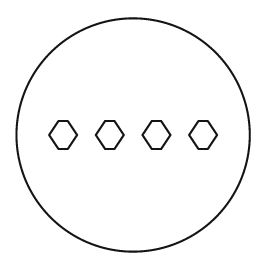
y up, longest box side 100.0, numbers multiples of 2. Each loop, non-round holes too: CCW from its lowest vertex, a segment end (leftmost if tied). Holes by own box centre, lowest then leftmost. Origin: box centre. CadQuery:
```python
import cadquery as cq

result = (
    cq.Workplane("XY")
    .moveTo(0.0, 0.0)
    .circle(50.0)
    .moveTo(-32.0, -6.0)
    .lineTo(-28.0, -6.0)
    .lineTo(-24.0, 0.0)
    .lineTo(-28.0, 6.0)
    .lineTo(-32.0, 6.0)
    .lineTo(-36.0, 0.0)
    .close()
    .moveTo(-12.0, -6.0)
    .lineTo(-8.0, -6.0)
    .lineTo(-4.0, 0.0)
    .lineTo(-8.0, 6.0)
    .lineTo(-12.0, 6.0)
    .lineTo(-16.0, 0.0)
    .close()
    .moveTo(8.0, -6.0)
    .lineTo(12.0, -6.0)
    .lineTo(16.0, 0.0)
    .lineTo(12.0, 6.0)
    .lineTo(8.0, 6.0)
    .lineTo(4.0, 0.0)
    .close()
    .moveTo(28.0, -6.0)
    .lineTo(32.0, -6.0)
    .lineTo(36.0, 0.0)
    .lineTo(32.0, 6.0)
    .lineTo(28.0, 6.0)
    .lineTo(24.0, 0.0)
    .close()
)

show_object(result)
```